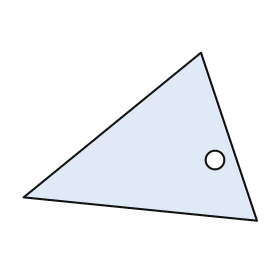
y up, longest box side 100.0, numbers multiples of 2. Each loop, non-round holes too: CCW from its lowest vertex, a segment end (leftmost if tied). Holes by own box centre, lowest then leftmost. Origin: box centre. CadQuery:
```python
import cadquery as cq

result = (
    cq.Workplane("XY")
    .moveTo(50.0, -36.0)
    .lineTo(26.0, 36.0)
    .lineTo(-50.0, -26.0)
    .close()
    .moveTo(32.0, -10.0)
    .circle(4.0)
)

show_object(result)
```